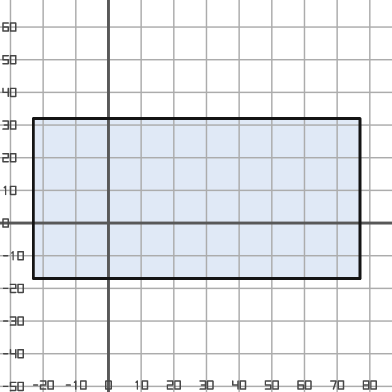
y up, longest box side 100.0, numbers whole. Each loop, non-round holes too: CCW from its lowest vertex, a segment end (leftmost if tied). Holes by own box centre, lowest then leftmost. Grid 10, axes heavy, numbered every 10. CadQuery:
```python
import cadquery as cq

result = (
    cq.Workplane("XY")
    .moveTo(-23.0, -17.0)
    .lineTo(77.0, -17.0)
    .lineTo(77.0, 32.0)
    .lineTo(-23.0, 32.0)
    .close()
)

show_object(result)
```